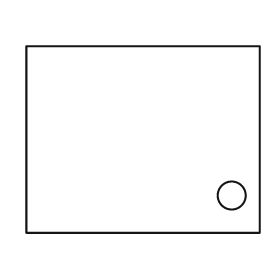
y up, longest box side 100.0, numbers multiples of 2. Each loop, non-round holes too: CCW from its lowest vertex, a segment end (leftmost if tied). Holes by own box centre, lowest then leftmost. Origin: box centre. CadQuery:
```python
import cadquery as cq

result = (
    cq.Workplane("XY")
    .moveTo(-50.0, -40.0)
    .lineTo(50.0, -40.0)
    .lineTo(50.0, 40.0)
    .lineTo(-50.0, 40.0)
    .close()
    .moveTo(38.0, -24.0)
    .circle(6.0)
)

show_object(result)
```